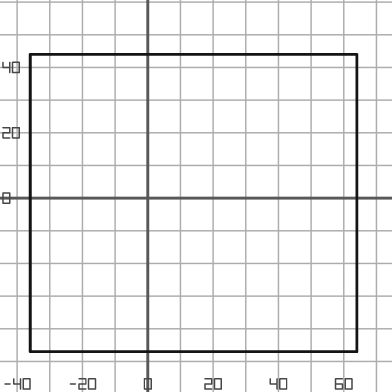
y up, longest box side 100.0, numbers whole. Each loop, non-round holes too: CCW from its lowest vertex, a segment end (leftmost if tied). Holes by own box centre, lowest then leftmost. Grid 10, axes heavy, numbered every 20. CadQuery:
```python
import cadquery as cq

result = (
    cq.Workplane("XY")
    .moveTo(-36.0, -47.0)
    .lineTo(64.0, -47.0)
    .lineTo(64.0, 44.0)
    .lineTo(-36.0, 44.0)
    .close()
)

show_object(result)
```